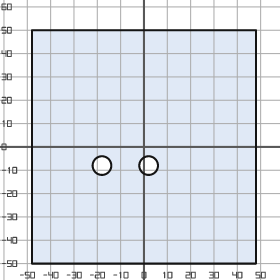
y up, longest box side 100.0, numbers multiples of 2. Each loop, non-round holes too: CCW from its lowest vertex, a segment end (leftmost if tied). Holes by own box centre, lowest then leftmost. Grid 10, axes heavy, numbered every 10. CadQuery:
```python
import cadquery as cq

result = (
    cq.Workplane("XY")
    .moveTo(-48.0, -50.0)
    .lineTo(48.0, -50.0)
    .lineTo(48.0, 50.0)
    .lineTo(-48.0, 50.0)
    .close()
    .moveTo(-18.0, -8.0)
    .circle(4.0)
    .moveTo(2.0, -8.0)
    .circle(4.0)
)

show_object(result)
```